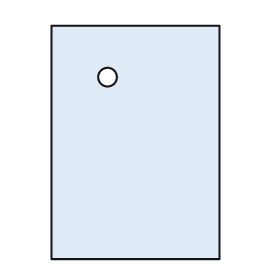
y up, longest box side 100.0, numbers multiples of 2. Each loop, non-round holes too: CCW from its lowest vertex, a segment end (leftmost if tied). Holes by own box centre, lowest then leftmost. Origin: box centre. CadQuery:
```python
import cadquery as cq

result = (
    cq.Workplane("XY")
    .moveTo(-36.0, -50.0)
    .lineTo(36.0, -50.0)
    .lineTo(36.0, 50.0)
    .lineTo(-36.0, 50.0)
    .close()
    .moveTo(-12.0, 28.0)
    .circle(4.0)
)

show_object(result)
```